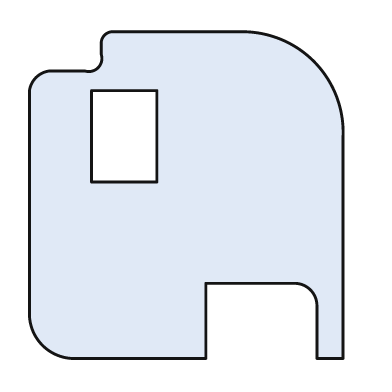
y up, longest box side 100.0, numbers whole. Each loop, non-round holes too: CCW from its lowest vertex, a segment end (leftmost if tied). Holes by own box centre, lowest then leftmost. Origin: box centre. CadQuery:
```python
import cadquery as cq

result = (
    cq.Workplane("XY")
    .moveTo(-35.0, -50.0)
    .lineTo(6.0, -50.0)
    .lineTo(6.0, -27.0)
    .lineTo(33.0, -27.0)
    .threePointArc((38.0, -29.0), (40.0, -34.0))
    .lineTo(40.0, -50.0)
    .lineTo(48.0, -50.0)
    .lineTo(48.0, 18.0)
    .threePointArc((39.0, 41.0), (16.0, 50.0))
    .lineTo(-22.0, 50.0)
    .threePointArc((-25.0, 49.0), (-26.0, 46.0))
    .lineTo(-26.0, 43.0)
    .threePointArc((-27.0, 39.0), (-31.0, 38.0))
    .lineTo(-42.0, 38.0)
    .threePointArc((-46.0, 36.0), (-48.0, 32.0))
    .lineTo(-48.0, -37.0)
    .threePointArc((-44.0, -46.0), (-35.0, -50.0))
    .close()
    .moveTo(-29.0, 4.0)
    .lineTo(-9.0, 4.0)
    .lineTo(-9.0, 32.0)
    .lineTo(-29.0, 32.0)
    .close()
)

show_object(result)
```